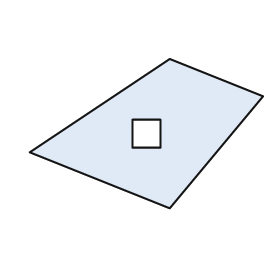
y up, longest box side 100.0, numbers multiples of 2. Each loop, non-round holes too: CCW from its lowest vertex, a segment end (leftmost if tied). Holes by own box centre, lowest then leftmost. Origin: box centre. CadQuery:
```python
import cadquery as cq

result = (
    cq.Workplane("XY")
    .moveTo(10.0, -32.0)
    .lineTo(50.0, 16.0)
    .lineTo(10.0, 32.0)
    .lineTo(-50.0, -8.0)
    .close()
    .moveTo(-6.0, -6.0)
    .lineTo(6.0, -6.0)
    .lineTo(6.0, 6.0)
    .lineTo(-6.0, 6.0)
    .close()
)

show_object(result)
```